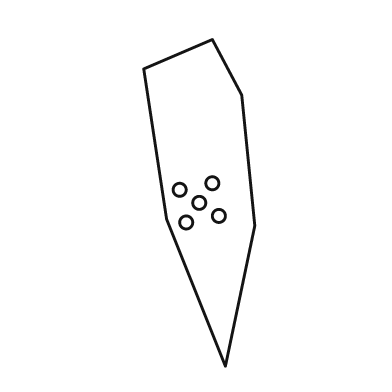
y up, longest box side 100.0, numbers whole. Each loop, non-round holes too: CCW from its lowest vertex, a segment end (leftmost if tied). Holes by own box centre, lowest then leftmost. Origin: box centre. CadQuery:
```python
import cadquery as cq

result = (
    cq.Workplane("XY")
    .moveTo(8.0, -50.0)
    .lineTo(17.0, -7.0)
    .lineTo(13.0, 33.0)
    .lineTo(4.0, 50.0)
    .lineTo(-17.0, 41.0)
    .lineTo(-10.0, -5.0)
    .close()
    .moveTo(-4.0, -6.0)
    .circle(2.0)
    .moveTo(6.0, -4.0)
    .circle(2.0)
    .moveTo(0.0, 0.0)
    .circle(2.0)
    .moveTo(-6.0, 4.0)
    .circle(2.0)
    .moveTo(4.0, 6.0)
    .circle(2.0)
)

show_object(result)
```